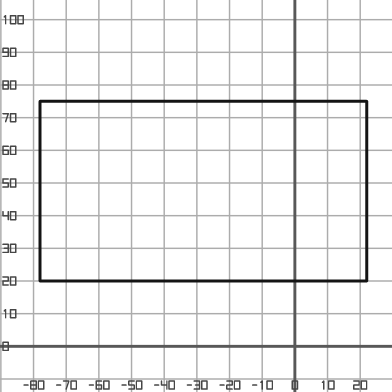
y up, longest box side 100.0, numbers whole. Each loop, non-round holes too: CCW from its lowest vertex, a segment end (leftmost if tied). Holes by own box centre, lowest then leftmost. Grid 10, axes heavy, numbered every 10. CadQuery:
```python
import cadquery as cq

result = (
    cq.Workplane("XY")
    .moveTo(-78.0, 20.0)
    .lineTo(22.0, 20.0)
    .lineTo(22.0, 75.0)
    .lineTo(-78.0, 75.0)
    .close()
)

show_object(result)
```